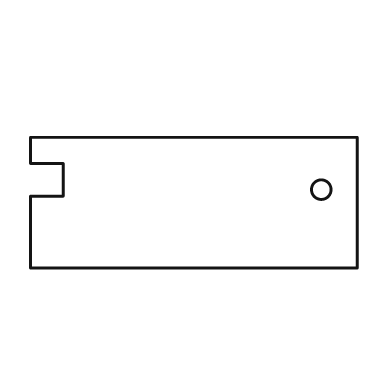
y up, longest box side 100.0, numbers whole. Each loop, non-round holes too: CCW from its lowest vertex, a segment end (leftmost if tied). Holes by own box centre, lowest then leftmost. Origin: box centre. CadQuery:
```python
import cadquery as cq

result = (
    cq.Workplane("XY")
    .moveTo(-50.0, -20.0)
    .lineTo(50.0, -20.0)
    .lineTo(50.0, 20.0)
    .lineTo(-50.0, 20.0)
    .lineTo(-50.0, 12.0)
    .lineTo(-40.0, 12.0)
    .lineTo(-40.0, 2.0)
    .lineTo(-50.0, 2.0)
    .close()
    .moveTo(39.0, 4.0)
    .circle(3.0)
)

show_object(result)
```